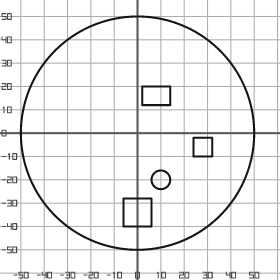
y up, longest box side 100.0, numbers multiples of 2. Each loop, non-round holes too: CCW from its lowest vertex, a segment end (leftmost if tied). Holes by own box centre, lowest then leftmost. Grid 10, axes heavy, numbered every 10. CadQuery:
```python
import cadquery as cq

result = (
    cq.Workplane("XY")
    .moveTo(0.0, 0.0)
    .circle(50.0)
    .moveTo(-6.0, -40.0)
    .lineTo(6.0, -40.0)
    .lineTo(6.0, -28.0)
    .lineTo(-6.0, -28.0)
    .close()
    .moveTo(10.0, -20.0)
    .circle(4.0)
    .moveTo(24.0, -10.0)
    .lineTo(32.0, -10.0)
    .lineTo(32.0, -2.0)
    .lineTo(24.0, -2.0)
    .close()
    .moveTo(2.0, 12.0)
    .lineTo(14.0, 12.0)
    .lineTo(14.0, 20.0)
    .lineTo(2.0, 20.0)
    .close()
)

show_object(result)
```